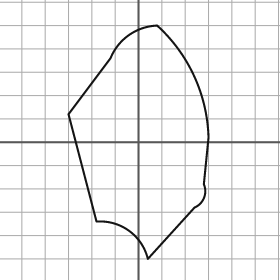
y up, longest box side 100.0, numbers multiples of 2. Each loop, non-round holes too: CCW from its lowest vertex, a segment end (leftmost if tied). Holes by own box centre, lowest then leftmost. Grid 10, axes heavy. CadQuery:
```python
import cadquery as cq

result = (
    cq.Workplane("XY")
    .moveTo(4.0, -50.0)
    .lineTo(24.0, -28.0)
    .threePointArc((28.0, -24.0), (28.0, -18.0))
    .lineTo(30.0, 2.0)
    .threePointArc((24.0, 28.0), (8.0, 50.0))
    .threePointArc((-4.0, 46.0), (-12.0, 36.0))
    .lineTo(-30.0, 12.0)
    .lineTo(-18.0, -34.0)
    .threePointArc((-4.0, -38.0), (4.0, -50.0))
    .close()
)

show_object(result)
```